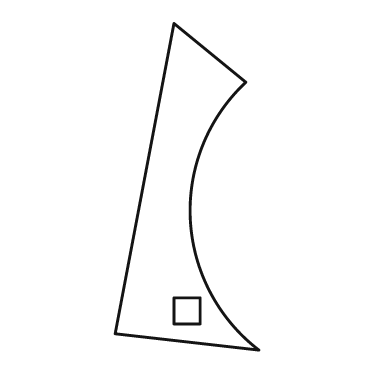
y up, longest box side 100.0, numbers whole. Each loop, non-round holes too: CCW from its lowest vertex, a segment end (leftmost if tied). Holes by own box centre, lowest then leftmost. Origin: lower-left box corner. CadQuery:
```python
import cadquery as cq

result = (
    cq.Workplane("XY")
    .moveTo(44.0, 0.0)
    .threePointArc((23.0, 40.0), (40.0, 82.0))
    .lineTo(18.0, 100.0)
    .lineTo(0.0, 5.0)
    .close()
    .moveTo(18.0, 8.0)
    .lineTo(26.0, 8.0)
    .lineTo(26.0, 16.0)
    .lineTo(18.0, 16.0)
    .close()
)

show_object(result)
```